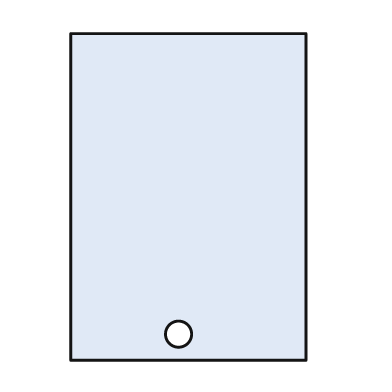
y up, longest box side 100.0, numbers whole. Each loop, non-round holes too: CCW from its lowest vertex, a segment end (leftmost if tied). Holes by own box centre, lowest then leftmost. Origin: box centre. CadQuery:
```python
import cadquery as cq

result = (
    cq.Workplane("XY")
    .moveTo(-36.0, -50.0)
    .lineTo(36.0, -50.0)
    .lineTo(36.0, 50.0)
    .lineTo(-36.0, 50.0)
    .close()
    .moveTo(-3.0, -42.0)
    .circle(4.0)
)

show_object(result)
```